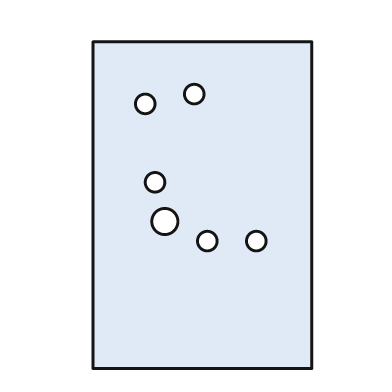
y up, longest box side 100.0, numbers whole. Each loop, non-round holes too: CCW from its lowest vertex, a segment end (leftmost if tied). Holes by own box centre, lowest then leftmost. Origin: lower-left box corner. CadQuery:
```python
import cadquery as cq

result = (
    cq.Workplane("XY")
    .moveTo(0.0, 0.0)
    .lineTo(67.0, 0.0)
    .lineTo(67.0, 100.0)
    .lineTo(0.0, 100.0)
    .close()
    .moveTo(35.0, 39.0)
    .circle(3.0)
    .moveTo(50.0, 39.0)
    .circle(3.0)
    .moveTo(22.0, 45.0)
    .circle(4.0)
    .moveTo(19.0, 57.0)
    .circle(3.0)
    .moveTo(16.0, 81.0)
    .circle(3.0)
    .moveTo(31.0, 84.0)
    .circle(3.0)
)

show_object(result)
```